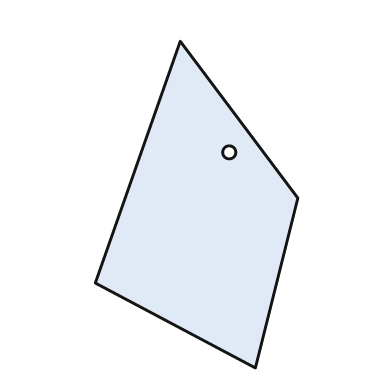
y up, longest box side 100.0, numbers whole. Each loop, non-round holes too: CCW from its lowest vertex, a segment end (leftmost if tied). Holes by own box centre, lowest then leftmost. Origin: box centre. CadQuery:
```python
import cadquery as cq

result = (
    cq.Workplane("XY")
    .moveTo(18.0, -50.0)
    .lineTo(31.0, 2.0)
    .lineTo(-5.0, 50.0)
    .lineTo(-31.0, -24.0)
    .close()
    .moveTo(10.0, 16.0)
    .circle(2.0)
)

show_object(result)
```